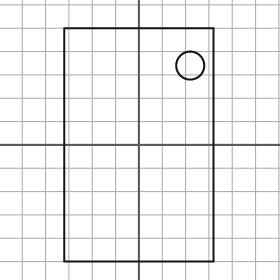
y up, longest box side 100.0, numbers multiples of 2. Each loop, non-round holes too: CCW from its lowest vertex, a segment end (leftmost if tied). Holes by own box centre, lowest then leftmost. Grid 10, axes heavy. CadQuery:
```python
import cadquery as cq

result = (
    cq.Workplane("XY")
    .moveTo(-32.0, -50.0)
    .lineTo(32.0, -50.0)
    .lineTo(32.0, 50.0)
    .lineTo(-32.0, 50.0)
    .close()
    .moveTo(22.0, 34.0)
    .circle(6.0)
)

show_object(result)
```